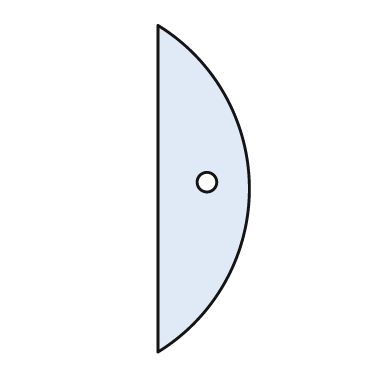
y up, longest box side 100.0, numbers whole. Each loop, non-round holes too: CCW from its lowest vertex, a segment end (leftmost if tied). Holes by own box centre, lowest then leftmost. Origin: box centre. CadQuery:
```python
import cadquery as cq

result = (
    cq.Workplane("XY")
    .moveTo(-14.0, -50.0)
    .threePointArc((14.0, 0.0), (-14.0, 50.0))
    .close()
    .moveTo(1.0, 2.0)
    .circle(3.0)
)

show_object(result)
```